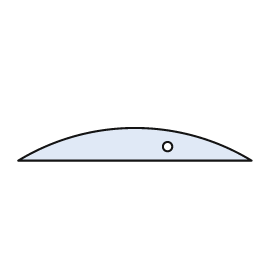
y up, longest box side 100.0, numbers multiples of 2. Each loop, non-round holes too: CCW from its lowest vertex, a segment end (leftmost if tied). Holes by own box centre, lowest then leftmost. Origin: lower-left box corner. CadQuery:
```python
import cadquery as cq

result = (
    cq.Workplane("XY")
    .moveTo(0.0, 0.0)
    .lineTo(100.0, 0.0)
    .threePointArc((50.0, 14.0), (0.0, 0.0))
    .close()
    .moveTo(64.0, 6.0)
    .circle(2.0)
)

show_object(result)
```